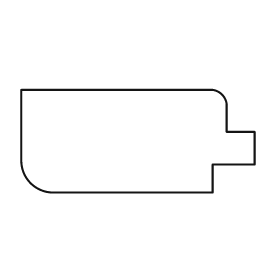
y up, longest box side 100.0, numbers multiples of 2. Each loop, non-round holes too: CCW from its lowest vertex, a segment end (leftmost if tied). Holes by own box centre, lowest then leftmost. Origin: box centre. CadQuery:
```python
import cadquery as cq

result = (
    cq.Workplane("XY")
    .moveTo(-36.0, -22.0)
    .lineTo(32.0, -22.0)
    .lineTo(32.0, -10.0)
    .lineTo(50.0, -10.0)
    .lineTo(50.0, 4.0)
    .lineTo(38.0, 4.0)
    .lineTo(38.0, 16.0)
    .threePointArc((36.0, 20.0), (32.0, 22.0))
    .lineTo(-50.0, 22.0)
    .lineTo(-50.0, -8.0)
    .threePointArc((-46.0, -18.0), (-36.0, -22.0))
    .close()
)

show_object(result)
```